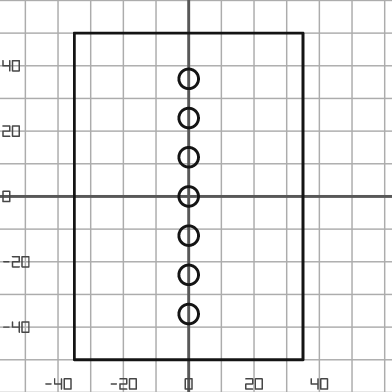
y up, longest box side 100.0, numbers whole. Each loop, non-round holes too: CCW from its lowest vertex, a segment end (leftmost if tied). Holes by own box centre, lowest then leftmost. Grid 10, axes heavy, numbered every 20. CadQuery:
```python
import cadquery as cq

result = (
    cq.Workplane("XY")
    .moveTo(-35.0, -50.0)
    .lineTo(35.0, -50.0)
    .lineTo(35.0, 50.0)
    .lineTo(-35.0, 50.0)
    .close()
    .moveTo(0.0, -36.0)
    .circle(3.0)
    .moveTo(0.0, -24.0)
    .circle(3.0)
    .moveTo(0.0, -12.0)
    .circle(3.0)
    .moveTo(0.0, 0.0)
    .circle(3.0)
    .moveTo(0.0, 12.0)
    .circle(3.0)
    .moveTo(0.0, 24.0)
    .circle(3.0)
    .moveTo(0.0, 36.0)
    .circle(3.0)
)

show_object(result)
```